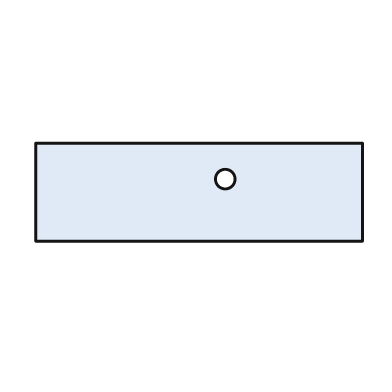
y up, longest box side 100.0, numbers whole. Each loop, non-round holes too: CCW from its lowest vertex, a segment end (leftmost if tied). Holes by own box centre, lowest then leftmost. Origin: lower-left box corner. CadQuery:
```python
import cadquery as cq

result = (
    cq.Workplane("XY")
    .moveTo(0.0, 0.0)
    .lineTo(100.0, 0.0)
    .lineTo(100.0, 30.0)
    .lineTo(0.0, 30.0)
    .close()
    .moveTo(58.0, 19.0)
    .circle(3.0)
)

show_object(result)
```